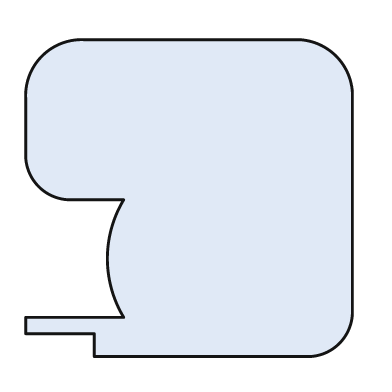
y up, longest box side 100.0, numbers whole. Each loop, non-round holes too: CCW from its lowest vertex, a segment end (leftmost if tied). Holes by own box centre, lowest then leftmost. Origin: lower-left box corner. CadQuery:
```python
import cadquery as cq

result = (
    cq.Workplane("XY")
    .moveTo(21.0, 0.0)
    .lineTo(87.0, 0.0)
    .threePointArc((96.0, 4.0), (100.0, 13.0))
    .lineTo(100.0, 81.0)
    .threePointArc((95.0, 92.0), (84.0, 97.0))
    .lineTo(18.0, 97.0)
    .threePointArc((5.0, 92.0), (0.0, 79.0))
    .lineTo(0.0, 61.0)
    .threePointArc((4.0, 52.0), (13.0, 48.0))
    .lineTo(30.0, 48.0)
    .threePointArc((25.0, 30.0), (30.0, 12.0))
    .lineTo(0.0, 12.0)
    .lineTo(0.0, 7.0)
    .lineTo(21.0, 7.0)
    .close()
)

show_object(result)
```